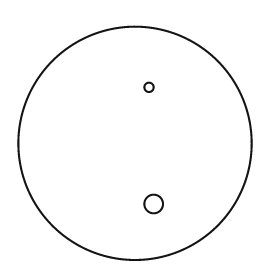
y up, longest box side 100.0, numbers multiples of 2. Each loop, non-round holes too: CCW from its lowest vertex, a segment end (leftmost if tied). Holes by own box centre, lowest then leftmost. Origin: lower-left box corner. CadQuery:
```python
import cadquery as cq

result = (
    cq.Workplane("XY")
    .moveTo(50.0, 50.0)
    .circle(50.0)
    .moveTo(58.0, 24.0)
    .circle(4.0)
    .moveTo(56.0, 74.0)
    .circle(2.0)
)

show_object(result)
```